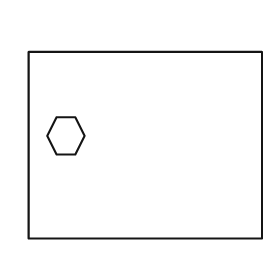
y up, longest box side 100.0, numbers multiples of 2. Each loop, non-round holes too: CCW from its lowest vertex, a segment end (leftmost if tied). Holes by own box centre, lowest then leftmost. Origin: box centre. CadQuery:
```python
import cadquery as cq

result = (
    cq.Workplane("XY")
    .moveTo(-50.0, -40.0)
    .lineTo(50.0, -40.0)
    .lineTo(50.0, 40.0)
    .lineTo(-50.0, 40.0)
    .close()
    .moveTo(-38.0, -4.0)
    .lineTo(-30.0, -4.0)
    .lineTo(-26.0, 4.0)
    .lineTo(-30.0, 12.0)
    .lineTo(-38.0, 12.0)
    .lineTo(-42.0, 4.0)
    .close()
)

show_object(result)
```